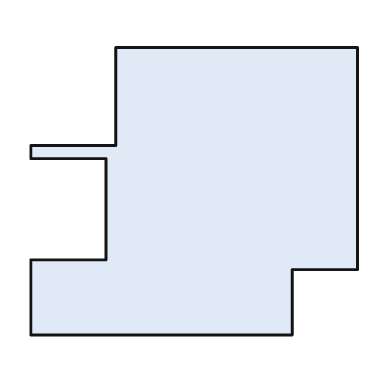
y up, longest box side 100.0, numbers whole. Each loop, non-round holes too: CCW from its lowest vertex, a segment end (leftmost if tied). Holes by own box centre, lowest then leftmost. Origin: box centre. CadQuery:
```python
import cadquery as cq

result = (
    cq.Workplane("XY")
    .moveTo(-50.0, -44.0)
    .lineTo(30.0, -44.0)
    .lineTo(30.0, -24.0)
    .lineTo(50.0, -24.0)
    .lineTo(50.0, 44.0)
    .lineTo(-24.0, 44.0)
    .lineTo(-24.0, 14.0)
    .lineTo(-50.0, 14.0)
    .lineTo(-50.0, 10.0)
    .lineTo(-27.0, 10.0)
    .lineTo(-27.0, -21.0)
    .lineTo(-50.0, -21.0)
    .close()
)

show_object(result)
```